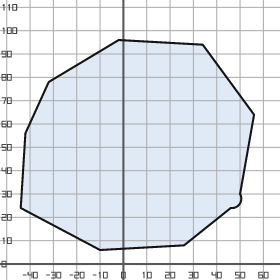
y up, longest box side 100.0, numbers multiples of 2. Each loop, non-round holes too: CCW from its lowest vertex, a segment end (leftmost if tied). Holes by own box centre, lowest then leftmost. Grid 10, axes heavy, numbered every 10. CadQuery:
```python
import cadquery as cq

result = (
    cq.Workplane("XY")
    .moveTo(-10.0, 6.0)
    .lineTo(26.0, 8.0)
    .lineTo(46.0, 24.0)
    .threePointArc((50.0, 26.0), (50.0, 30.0))
    .lineTo(56.0, 64.0)
    .lineTo(34.0, 94.0)
    .lineTo(-2.0, 96.0)
    .lineTo(-32.0, 78.0)
    .lineTo(-42.0, 56.0)
    .lineTo(-44.0, 24.0)
    .close()
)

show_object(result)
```